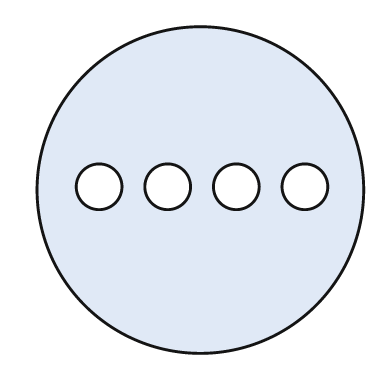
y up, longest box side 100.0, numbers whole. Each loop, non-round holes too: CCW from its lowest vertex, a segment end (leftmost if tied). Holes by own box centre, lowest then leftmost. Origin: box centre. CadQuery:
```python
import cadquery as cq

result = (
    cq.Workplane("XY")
    .moveTo(0.0, 0.0)
    .circle(50.0)
    .moveTo(-31.0, 1.0)
    .circle(7.0)
    .moveTo(-10.0, 1.0)
    .circle(7.0)
    .moveTo(11.0, 1.0)
    .circle(7.0)
    .moveTo(32.0, 1.0)
    .circle(7.0)
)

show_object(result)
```